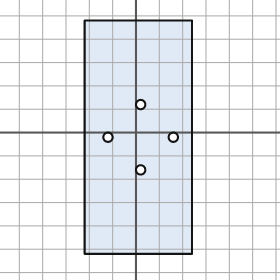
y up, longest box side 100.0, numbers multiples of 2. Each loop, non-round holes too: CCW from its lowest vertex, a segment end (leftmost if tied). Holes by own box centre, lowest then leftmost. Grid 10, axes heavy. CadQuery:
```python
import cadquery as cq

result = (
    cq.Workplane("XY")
    .moveTo(-22.0, -52.0)
    .lineTo(24.0, -52.0)
    .lineTo(24.0, 48.0)
    .lineTo(-22.0, 48.0)
    .close()
    .moveTo(2.0, -16.0)
    .circle(2.0)
    .moveTo(-12.0, -2.0)
    .circle(2.0)
    .moveTo(16.0, -2.0)
    .circle(2.0)
    .moveTo(2.0, 12.0)
    .circle(2.0)
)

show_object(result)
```